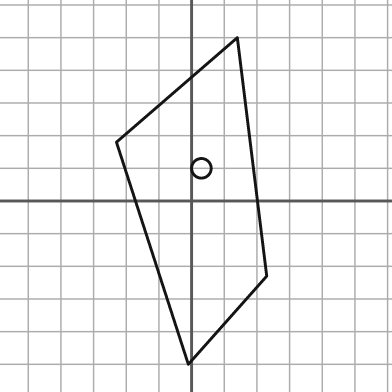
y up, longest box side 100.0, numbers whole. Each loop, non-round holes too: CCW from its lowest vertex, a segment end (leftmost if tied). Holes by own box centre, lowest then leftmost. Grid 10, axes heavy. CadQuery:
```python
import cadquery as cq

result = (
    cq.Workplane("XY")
    .moveTo(-1.0, -50.0)
    .lineTo(23.0, -23.0)
    .lineTo(14.0, 50.0)
    .lineTo(-23.0, 18.0)
    .close()
    .moveTo(3.0, 10.0)
    .circle(3.0)
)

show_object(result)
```